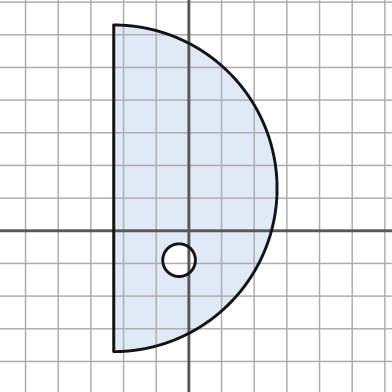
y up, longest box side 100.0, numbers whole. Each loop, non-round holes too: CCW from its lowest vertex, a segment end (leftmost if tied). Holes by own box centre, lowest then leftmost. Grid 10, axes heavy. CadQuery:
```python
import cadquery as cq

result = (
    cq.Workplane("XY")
    .moveTo(-23.0, -37.0)
    .threePointArc((27.0, 13.0), (-23.0, 63.0))
    .close()
    .moveTo(-3.0, -9.0)
    .circle(5.0)
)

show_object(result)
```